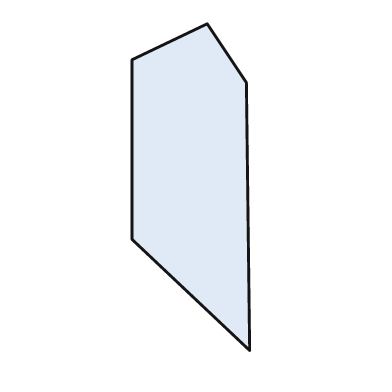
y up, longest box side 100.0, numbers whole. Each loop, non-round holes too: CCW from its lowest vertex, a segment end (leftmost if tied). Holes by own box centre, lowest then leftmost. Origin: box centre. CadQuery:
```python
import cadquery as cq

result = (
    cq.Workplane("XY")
    .moveTo(18.0, -50.0)
    .lineTo(17.0, 32.0)
    .lineTo(5.0, 50.0)
    .lineTo(-18.0, 39.0)
    .lineTo(-18.0, -16.0)
    .close()
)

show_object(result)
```